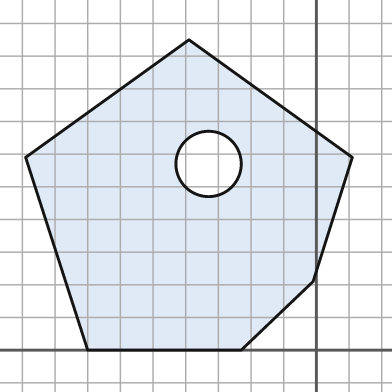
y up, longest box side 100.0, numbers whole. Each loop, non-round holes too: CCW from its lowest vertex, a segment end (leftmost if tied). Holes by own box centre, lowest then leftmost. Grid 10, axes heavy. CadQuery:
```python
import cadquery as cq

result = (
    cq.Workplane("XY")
    .moveTo(-70.0, 0.0)
    .lineTo(-23.0, 0.0)
    .lineTo(-1.0, 21.0)
    .lineTo(11.0, 59.0)
    .lineTo(-39.0, 95.0)
    .lineTo(-89.0, 59.0)
    .close()
    .moveTo(-33.0, 57.0)
    .circle(10.0)
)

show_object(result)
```